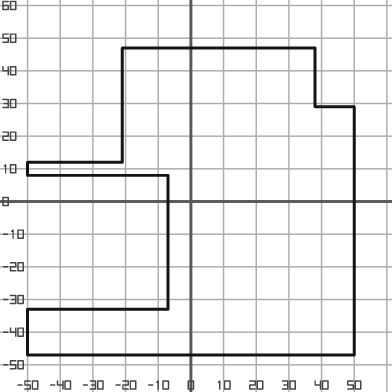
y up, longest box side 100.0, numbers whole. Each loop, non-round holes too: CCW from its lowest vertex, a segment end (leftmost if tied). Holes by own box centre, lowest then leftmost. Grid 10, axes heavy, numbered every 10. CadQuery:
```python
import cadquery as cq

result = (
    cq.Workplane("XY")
    .moveTo(-50.0, -47.0)
    .lineTo(50.0, -47.0)
    .lineTo(50.0, 29.0)
    .lineTo(38.0, 29.0)
    .lineTo(38.0, 47.0)
    .lineTo(-21.0, 47.0)
    .lineTo(-21.0, 12.0)
    .lineTo(-50.0, 12.0)
    .lineTo(-50.0, 8.0)
    .lineTo(-7.0, 8.0)
    .lineTo(-7.0, -33.0)
    .lineTo(-50.0, -33.0)
    .close()
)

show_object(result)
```